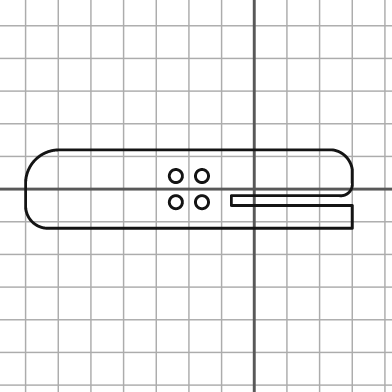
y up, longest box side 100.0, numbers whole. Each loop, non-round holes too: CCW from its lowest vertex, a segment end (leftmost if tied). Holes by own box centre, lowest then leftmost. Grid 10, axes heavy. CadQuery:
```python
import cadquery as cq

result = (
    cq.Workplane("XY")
    .moveTo(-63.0, -12.0)
    .lineTo(30.0, -12.0)
    .lineTo(30.0, -5.0)
    .lineTo(-7.0, -5.0)
    .lineTo(-7.0, -2.0)
    .lineTo(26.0, -2.0)
    .threePointArc((29.0, -1.0), (30.0, 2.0))
    .lineTo(30.0, 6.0)
    .threePointArc((28.0, 10.0), (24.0, 12.0))
    .lineTo(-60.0, 12.0)
    .threePointArc((-67.0, 9.0), (-70.0, 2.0))
    .lineTo(-70.0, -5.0)
    .threePointArc((-68.0, -10.0), (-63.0, -12.0))
    .close()
    .moveTo(-24.0, -4.0)
    .circle(2.0)
    .moveTo(-16.0, -4.0)
    .circle(2.0)
    .moveTo(-24.0, 4.0)
    .circle(2.0)
    .moveTo(-16.0, 4.0)
    .circle(2.0)
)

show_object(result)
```